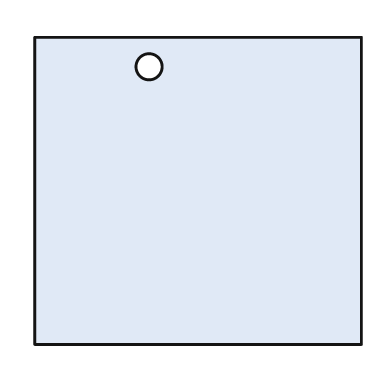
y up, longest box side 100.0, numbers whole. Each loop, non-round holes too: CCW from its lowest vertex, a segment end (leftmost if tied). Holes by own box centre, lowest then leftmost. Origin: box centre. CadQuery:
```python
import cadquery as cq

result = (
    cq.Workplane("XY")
    .moveTo(-50.0, -47.0)
    .lineTo(50.0, -47.0)
    .lineTo(50.0, 47.0)
    .lineTo(-50.0, 47.0)
    .close()
    .moveTo(-15.0, 38.0)
    .circle(4.0)
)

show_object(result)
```